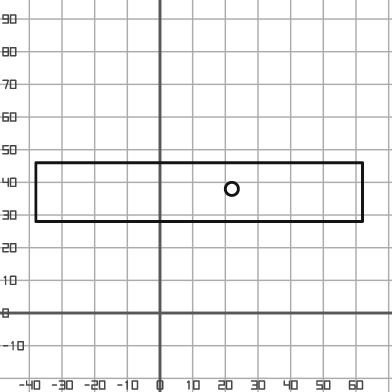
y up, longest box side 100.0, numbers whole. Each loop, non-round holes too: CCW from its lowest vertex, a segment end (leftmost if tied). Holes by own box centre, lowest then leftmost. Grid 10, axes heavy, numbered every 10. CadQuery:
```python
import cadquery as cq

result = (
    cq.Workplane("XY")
    .moveTo(-38.0, 28.0)
    .lineTo(62.0, 28.0)
    .lineTo(62.0, 46.0)
    .lineTo(-38.0, 46.0)
    .close()
    .moveTo(22.0, 38.0)
    .circle(2.0)
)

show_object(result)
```